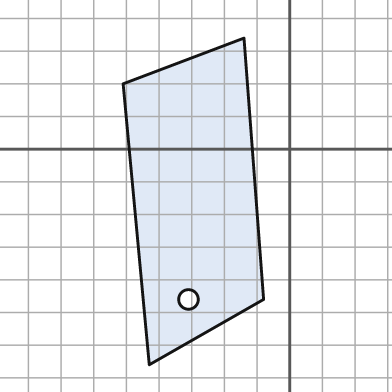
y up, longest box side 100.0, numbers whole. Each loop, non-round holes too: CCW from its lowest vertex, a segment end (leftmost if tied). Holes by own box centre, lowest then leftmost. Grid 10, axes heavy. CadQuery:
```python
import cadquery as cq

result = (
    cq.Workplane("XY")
    .moveTo(-43.0, -66.0)
    .lineTo(-8.0, -46.0)
    .lineTo(-14.0, 34.0)
    .lineTo(-51.0, 20.0)
    .close()
    .moveTo(-31.0, -46.0)
    .circle(3.0)
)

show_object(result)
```